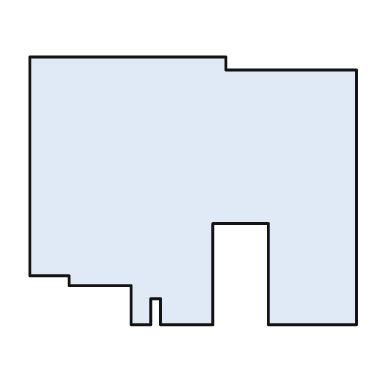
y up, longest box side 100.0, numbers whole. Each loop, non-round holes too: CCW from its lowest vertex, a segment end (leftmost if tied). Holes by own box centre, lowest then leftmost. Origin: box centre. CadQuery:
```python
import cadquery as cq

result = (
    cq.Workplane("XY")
    .moveTo(-19.0, -41.0)
    .lineTo(-13.0, -41.0)
    .lineTo(-13.0, -33.0)
    .lineTo(-10.0, -33.0)
    .lineTo(-10.0, -41.0)
    .lineTo(6.0, -41.0)
    .lineTo(6.0, -10.0)
    .lineTo(23.0, -10.0)
    .lineTo(23.0, -41.0)
    .lineTo(50.0, -41.0)
    .lineTo(50.0, 37.0)
    .lineTo(10.0, 37.0)
    .lineTo(10.0, 41.0)
    .lineTo(-50.0, 41.0)
    .lineTo(-50.0, -26.0)
    .lineTo(-38.0, -26.0)
    .lineTo(-38.0, -29.0)
    .lineTo(-19.0, -29.0)
    .close()
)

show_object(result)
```